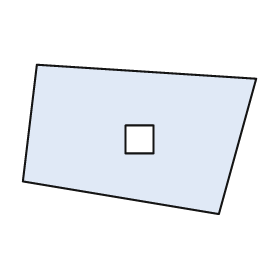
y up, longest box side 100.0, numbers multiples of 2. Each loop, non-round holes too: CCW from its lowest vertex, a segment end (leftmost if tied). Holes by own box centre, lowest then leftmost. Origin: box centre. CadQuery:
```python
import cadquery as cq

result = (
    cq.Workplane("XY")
    .moveTo(34.0, -32.0)
    .lineTo(50.0, 26.0)
    .lineTo(-44.0, 32.0)
    .lineTo(-50.0, -18.0)
    .close()
    .moveTo(-6.0, -6.0)
    .lineTo(6.0, -6.0)
    .lineTo(6.0, 6.0)
    .lineTo(-6.0, 6.0)
    .close()
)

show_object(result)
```